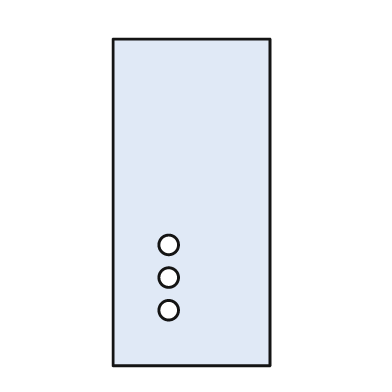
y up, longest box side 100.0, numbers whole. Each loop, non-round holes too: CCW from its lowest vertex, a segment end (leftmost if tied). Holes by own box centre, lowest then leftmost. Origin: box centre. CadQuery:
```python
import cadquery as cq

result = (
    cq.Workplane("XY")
    .moveTo(-24.0, -50.0)
    .lineTo(24.0, -50.0)
    .lineTo(24.0, 50.0)
    .lineTo(-24.0, 50.0)
    .close()
    .moveTo(-7.0, -33.0)
    .circle(3.0)
    .moveTo(-7.0, -23.0)
    .circle(3.0)
    .moveTo(-7.0, -13.0)
    .circle(3.0)
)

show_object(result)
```